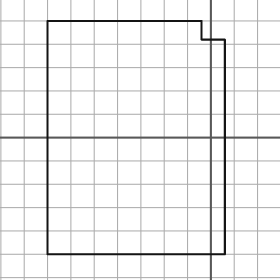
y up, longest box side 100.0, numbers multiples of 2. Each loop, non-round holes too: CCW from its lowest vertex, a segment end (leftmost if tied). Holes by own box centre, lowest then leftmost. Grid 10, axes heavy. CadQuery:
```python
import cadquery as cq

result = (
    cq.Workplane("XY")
    .moveTo(-70.0, -50.0)
    .lineTo(6.0, -50.0)
    .lineTo(6.0, 42.0)
    .lineTo(-4.0, 42.0)
    .lineTo(-4.0, 50.0)
    .lineTo(-70.0, 50.0)
    .close()
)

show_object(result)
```